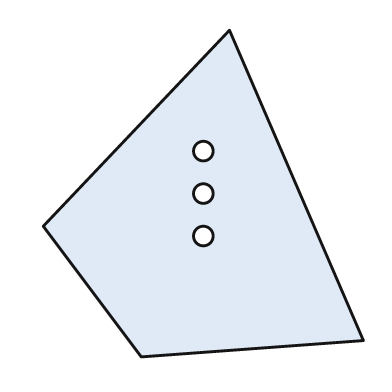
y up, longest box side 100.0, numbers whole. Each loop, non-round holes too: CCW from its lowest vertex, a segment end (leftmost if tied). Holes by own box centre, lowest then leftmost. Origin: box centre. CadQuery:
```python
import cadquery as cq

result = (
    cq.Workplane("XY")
    .moveTo(-19.0, -50.0)
    .lineTo(49.0, -45.0)
    .lineTo(8.0, 50.0)
    .lineTo(-49.0, -10.0)
    .close()
    .moveTo(0.0, -13.0)
    .circle(3.0)
    .moveTo(0.0, 0.0)
    .circle(3.0)
    .moveTo(0.0, 13.0)
    .circle(3.0)
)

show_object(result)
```